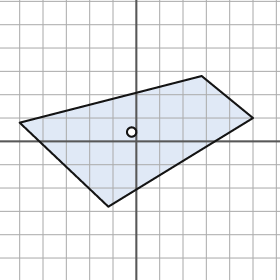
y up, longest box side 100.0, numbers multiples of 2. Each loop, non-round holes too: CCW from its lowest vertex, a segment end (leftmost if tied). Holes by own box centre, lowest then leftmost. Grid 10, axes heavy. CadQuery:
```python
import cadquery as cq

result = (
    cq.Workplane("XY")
    .moveTo(-12.0, -28.0)
    .lineTo(50.0, 10.0)
    .lineTo(28.0, 28.0)
    .lineTo(-50.0, 8.0)
    .close()
    .moveTo(-2.0, 4.0)
    .circle(2.0)
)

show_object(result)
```